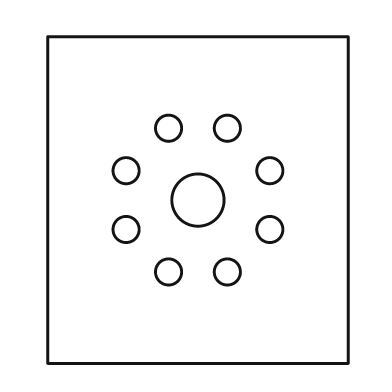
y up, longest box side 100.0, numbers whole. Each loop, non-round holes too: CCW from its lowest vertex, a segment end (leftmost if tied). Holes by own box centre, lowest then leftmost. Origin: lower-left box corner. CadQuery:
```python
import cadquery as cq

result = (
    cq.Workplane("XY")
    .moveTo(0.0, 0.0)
    .lineTo(92.0, 0.0)
    .lineTo(92.0, 100.0)
    .lineTo(0.0, 100.0)
    .close()
    .moveTo(37.0, 28.0)
    .circle(4.0)
    .moveTo(55.0, 28.0)
    .circle(4.0)
    .moveTo(24.0, 41.0)
    .circle(4.0)
    .moveTo(68.0, 41.0)
    .circle(4.0)
    .moveTo(46.0, 50.0)
    .circle(8.0)
    .moveTo(24.0, 59.0)
    .circle(4.0)
    .moveTo(68.0, 59.0)
    .circle(4.0)
    .moveTo(37.0, 72.0)
    .circle(4.0)
    .moveTo(55.0, 72.0)
    .circle(4.0)
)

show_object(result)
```